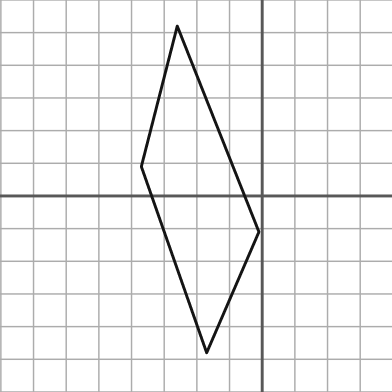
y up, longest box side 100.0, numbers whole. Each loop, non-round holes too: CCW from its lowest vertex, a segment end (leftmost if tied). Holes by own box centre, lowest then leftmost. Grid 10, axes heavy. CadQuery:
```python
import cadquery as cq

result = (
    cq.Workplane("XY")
    .moveTo(-17.0, -48.0)
    .lineTo(-1.0, -11.0)
    .lineTo(-26.0, 52.0)
    .lineTo(-37.0, 9.0)
    .close()
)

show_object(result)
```